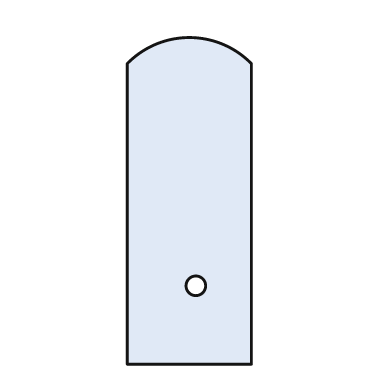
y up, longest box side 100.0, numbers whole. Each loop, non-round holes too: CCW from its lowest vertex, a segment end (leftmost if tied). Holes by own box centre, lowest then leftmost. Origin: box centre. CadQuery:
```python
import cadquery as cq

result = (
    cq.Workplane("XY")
    .moveTo(-19.0, -50.0)
    .lineTo(19.0, -50.0)
    .lineTo(19.0, 42.0)
    .threePointArc((0.0, 50.0), (-19.0, 42.0))
    .close()
    .moveTo(2.0, -26.0)
    .circle(3.0)
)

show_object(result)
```